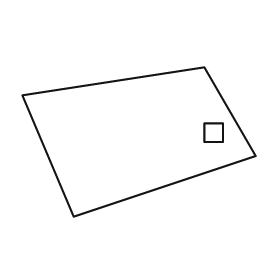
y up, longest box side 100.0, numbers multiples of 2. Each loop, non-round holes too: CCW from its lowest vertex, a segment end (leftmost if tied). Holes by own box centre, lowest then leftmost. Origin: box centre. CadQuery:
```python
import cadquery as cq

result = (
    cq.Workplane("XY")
    .moveTo(-28.0, -32.0)
    .lineTo(50.0, -6.0)
    .lineTo(28.0, 32.0)
    .lineTo(-50.0, 20.0)
    .close()
    .moveTo(28.0, 0.0)
    .lineTo(36.0, 0.0)
    .lineTo(36.0, 8.0)
    .lineTo(28.0, 8.0)
    .close()
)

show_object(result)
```